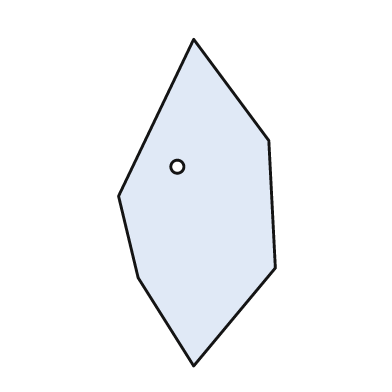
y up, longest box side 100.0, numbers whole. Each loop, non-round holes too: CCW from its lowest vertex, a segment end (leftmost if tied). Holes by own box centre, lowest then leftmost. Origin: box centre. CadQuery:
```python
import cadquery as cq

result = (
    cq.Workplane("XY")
    .moveTo(-1.0, -50.0)
    .lineTo(24.0, -20.0)
    .lineTo(22.0, 19.0)
    .lineTo(-1.0, 50.0)
    .lineTo(-24.0, 2.0)
    .lineTo(-18.0, -23.0)
    .close()
    .moveTo(-6.0, 11.0)
    .circle(2.0)
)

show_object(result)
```